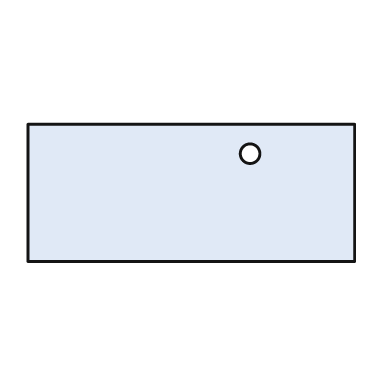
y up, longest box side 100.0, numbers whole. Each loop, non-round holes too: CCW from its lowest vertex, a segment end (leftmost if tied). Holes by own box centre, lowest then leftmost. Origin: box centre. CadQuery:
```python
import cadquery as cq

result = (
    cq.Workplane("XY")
    .moveTo(-50.0, -21.0)
    .lineTo(50.0, -21.0)
    .lineTo(50.0, 21.0)
    .lineTo(-50.0, 21.0)
    .close()
    .moveTo(18.0, 12.0)
    .circle(3.0)
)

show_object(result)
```